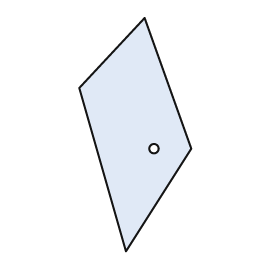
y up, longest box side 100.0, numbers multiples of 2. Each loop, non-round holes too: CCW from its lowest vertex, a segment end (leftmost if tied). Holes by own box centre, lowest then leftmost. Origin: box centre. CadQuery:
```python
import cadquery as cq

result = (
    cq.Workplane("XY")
    .moveTo(-4.0, -50.0)
    .lineTo(24.0, -6.0)
    .lineTo(4.0, 50.0)
    .lineTo(-24.0, 20.0)
    .close()
    .moveTo(8.0, -6.0)
    .circle(2.0)
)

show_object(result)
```